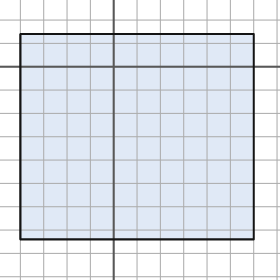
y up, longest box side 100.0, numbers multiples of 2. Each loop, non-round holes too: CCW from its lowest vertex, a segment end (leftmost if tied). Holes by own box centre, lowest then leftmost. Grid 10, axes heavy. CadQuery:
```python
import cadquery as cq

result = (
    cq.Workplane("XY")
    .moveTo(-40.0, -74.0)
    .lineTo(60.0, -74.0)
    .lineTo(60.0, 14.0)
    .lineTo(-40.0, 14.0)
    .close()
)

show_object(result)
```